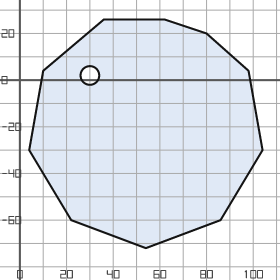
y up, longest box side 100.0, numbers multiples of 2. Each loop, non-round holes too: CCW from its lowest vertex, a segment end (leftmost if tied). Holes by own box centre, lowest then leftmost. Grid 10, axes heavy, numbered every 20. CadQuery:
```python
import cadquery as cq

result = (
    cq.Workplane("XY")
    .moveTo(54.0, -72.0)
    .lineTo(86.0, -60.0)
    .lineTo(104.0, -30.0)
    .lineTo(98.0, 4.0)
    .lineTo(80.0, 20.0)
    .lineTo(62.0, 26.0)
    .lineTo(36.0, 26.0)
    .lineTo(10.0, 4.0)
    .lineTo(4.0, -30.0)
    .lineTo(22.0, -60.0)
    .close()
    .moveTo(30.0, 2.0)
    .circle(4.0)
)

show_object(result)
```